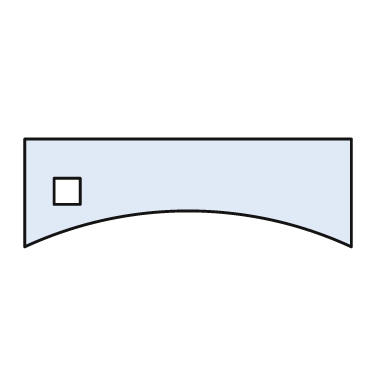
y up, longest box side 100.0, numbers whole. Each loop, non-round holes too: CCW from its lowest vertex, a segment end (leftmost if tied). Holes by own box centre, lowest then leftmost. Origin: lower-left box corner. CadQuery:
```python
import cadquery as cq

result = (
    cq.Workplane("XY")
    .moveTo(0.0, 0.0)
    .threePointArc((50.0, 11.0), (100.0, 0.0))
    .lineTo(100.0, 33.0)
    .lineTo(0.0, 33.0)
    .close()
    .moveTo(9.0, 13.0)
    .lineTo(17.0, 13.0)
    .lineTo(17.0, 21.0)
    .lineTo(9.0, 21.0)
    .close()
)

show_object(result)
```